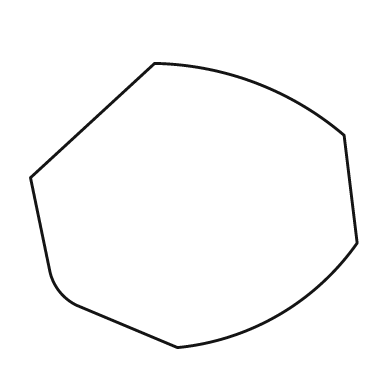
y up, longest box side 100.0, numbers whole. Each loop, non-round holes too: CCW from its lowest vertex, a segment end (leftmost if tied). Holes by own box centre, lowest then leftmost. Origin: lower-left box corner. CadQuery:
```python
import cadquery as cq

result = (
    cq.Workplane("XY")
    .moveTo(45.0, 0.0)
    .threePointArc((76.0, 10.0), (100.0, 32.0))
    .lineTo(96.0, 65.0)
    .threePointArc((69.0, 81.0), (38.0, 87.0))
    .lineTo(0.0, 52.0)
    .lineTo(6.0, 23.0)
    .threePointArc((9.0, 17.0), (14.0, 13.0))
    .close()
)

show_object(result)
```